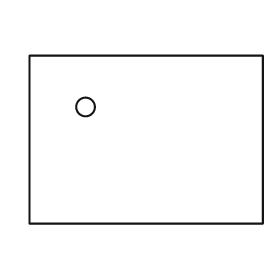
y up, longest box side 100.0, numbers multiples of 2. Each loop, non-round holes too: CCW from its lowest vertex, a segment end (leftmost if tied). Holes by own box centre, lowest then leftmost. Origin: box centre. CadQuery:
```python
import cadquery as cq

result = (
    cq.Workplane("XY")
    .moveTo(-50.0, -36.0)
    .lineTo(50.0, -36.0)
    .lineTo(50.0, 36.0)
    .lineTo(-50.0, 36.0)
    .close()
    .moveTo(-26.0, 14.0)
    .circle(4.0)
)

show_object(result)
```